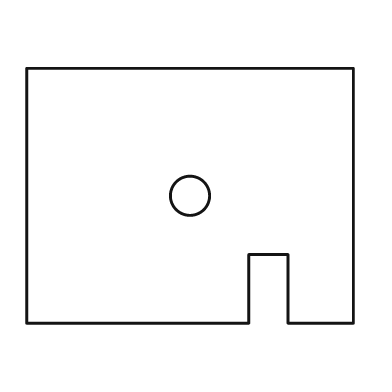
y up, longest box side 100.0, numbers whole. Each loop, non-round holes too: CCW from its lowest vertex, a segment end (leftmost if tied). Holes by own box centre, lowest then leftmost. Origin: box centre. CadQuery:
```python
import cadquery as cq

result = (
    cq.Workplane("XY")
    .moveTo(-50.0, -39.0)
    .lineTo(18.0, -39.0)
    .lineTo(18.0, -18.0)
    .lineTo(30.0, -18.0)
    .lineTo(30.0, -39.0)
    .lineTo(50.0, -39.0)
    .lineTo(50.0, 39.0)
    .lineTo(-50.0, 39.0)
    .close()
    .moveTo(0.0, 0.0)
    .circle(6.0)
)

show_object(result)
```